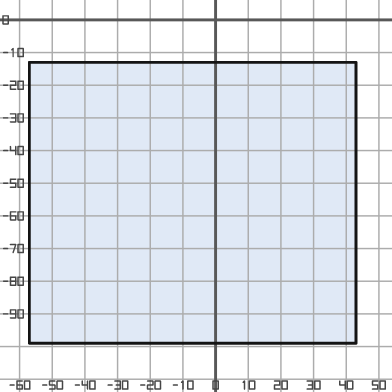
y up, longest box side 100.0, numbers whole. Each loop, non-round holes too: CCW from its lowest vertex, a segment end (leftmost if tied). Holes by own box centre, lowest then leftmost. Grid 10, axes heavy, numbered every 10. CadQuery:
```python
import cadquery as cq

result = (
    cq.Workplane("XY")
    .moveTo(-57.0, -99.0)
    .lineTo(43.0, -99.0)
    .lineTo(43.0, -13.0)
    .lineTo(-57.0, -13.0)
    .close()
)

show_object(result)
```